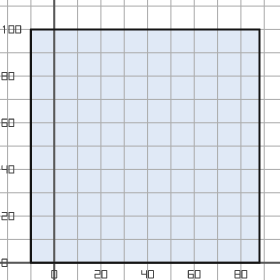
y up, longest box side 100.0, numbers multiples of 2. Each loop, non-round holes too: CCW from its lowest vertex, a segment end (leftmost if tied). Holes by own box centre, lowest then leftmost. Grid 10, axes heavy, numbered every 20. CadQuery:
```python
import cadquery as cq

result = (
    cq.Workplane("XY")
    .moveTo(-10.0, 0.0)
    .lineTo(88.0, 0.0)
    .lineTo(88.0, 100.0)
    .lineTo(-10.0, 100.0)
    .close()
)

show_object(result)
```